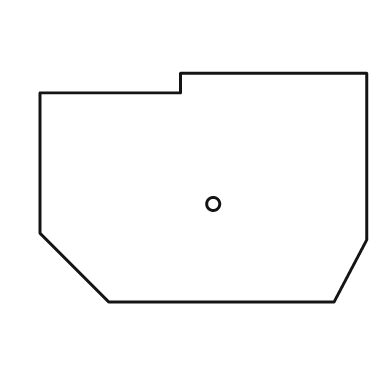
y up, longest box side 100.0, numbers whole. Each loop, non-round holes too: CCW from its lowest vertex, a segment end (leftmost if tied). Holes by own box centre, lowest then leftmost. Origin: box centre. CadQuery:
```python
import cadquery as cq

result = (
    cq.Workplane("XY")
    .moveTo(-29.0, -35.0)
    .lineTo(40.0, -35.0)
    .lineTo(50.0, -16.0)
    .lineTo(50.0, 35.0)
    .lineTo(-7.0, 35.0)
    .lineTo(-7.0, 29.0)
    .lineTo(-50.0, 29.0)
    .lineTo(-50.0, -14.0)
    .close()
    .moveTo(3.0, -5.0)
    .circle(2.0)
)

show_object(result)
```